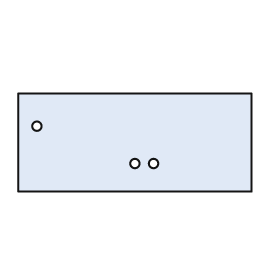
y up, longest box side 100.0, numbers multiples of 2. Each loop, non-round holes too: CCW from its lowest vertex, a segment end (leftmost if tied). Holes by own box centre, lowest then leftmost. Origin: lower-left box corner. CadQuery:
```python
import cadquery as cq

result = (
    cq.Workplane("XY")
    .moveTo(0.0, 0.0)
    .lineTo(100.0, 0.0)
    .lineTo(100.0, 42.0)
    .lineTo(0.0, 42.0)
    .close()
    .moveTo(50.0, 12.0)
    .circle(2.0)
    .moveTo(58.0, 12.0)
    .circle(2.0)
    .moveTo(8.0, 28.0)
    .circle(2.0)
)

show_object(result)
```